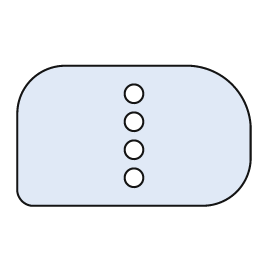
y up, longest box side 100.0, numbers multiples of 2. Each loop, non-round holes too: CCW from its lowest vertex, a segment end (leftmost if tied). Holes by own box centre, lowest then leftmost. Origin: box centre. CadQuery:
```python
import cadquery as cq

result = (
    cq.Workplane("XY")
    .moveTo(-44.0, -30.0)
    .lineTo(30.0, -30.0)
    .threePointArc((44.0, -24.0), (50.0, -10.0))
    .lineTo(50.0, 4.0)
    .threePointArc((42.0, 22.0), (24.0, 30.0))
    .lineTo(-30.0, 30.0)
    .threePointArc((-44.0, 24.0), (-50.0, 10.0))
    .lineTo(-50.0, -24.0)
    .threePointArc((-48.0, -28.0), (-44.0, -30.0))
    .close()
    .moveTo(0.0, -18.0)
    .circle(4.0)
    .moveTo(0.0, -6.0)
    .circle(4.0)
    .moveTo(0.0, 6.0)
    .circle(4.0)
    .moveTo(0.0, 18.0)
    .circle(4.0)
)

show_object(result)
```